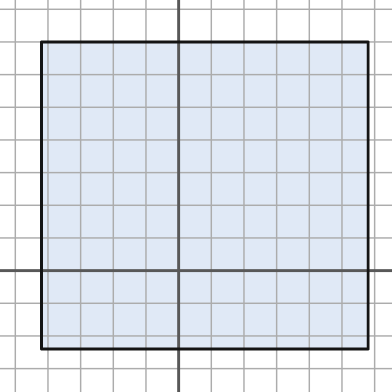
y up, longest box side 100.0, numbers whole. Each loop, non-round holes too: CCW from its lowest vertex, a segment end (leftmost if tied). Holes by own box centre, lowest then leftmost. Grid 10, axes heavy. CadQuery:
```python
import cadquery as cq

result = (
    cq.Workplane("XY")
    .moveTo(-42.0, -24.0)
    .lineTo(58.0, -24.0)
    .lineTo(58.0, 70.0)
    .lineTo(-42.0, 70.0)
    .close()
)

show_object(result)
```